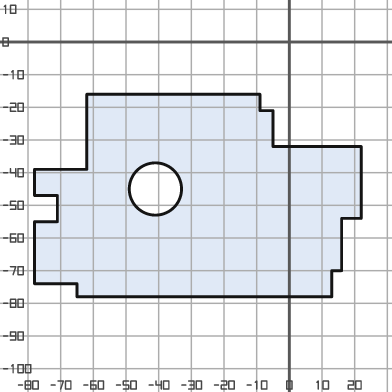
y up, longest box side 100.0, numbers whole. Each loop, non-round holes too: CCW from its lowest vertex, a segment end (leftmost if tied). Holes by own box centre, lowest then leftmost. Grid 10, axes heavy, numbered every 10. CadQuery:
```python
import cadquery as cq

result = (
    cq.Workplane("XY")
    .moveTo(-65.0, -78.0)
    .lineTo(13.0, -78.0)
    .lineTo(13.0, -70.0)
    .lineTo(16.0, -70.0)
    .lineTo(16.0, -54.0)
    .lineTo(22.0, -54.0)
    .lineTo(22.0, -32.0)
    .lineTo(-5.0, -32.0)
    .lineTo(-5.0, -21.0)
    .lineTo(-9.0, -21.0)
    .lineTo(-9.0, -16.0)
    .lineTo(-62.0, -16.0)
    .lineTo(-62.0, -39.0)
    .lineTo(-78.0, -39.0)
    .lineTo(-78.0, -47.0)
    .lineTo(-71.0, -47.0)
    .lineTo(-71.0, -55.0)
    .lineTo(-78.0, -55.0)
    .lineTo(-78.0, -74.0)
    .lineTo(-65.0, -74.0)
    .close()
    .moveTo(-41.0, -45.0)
    .circle(8.0)
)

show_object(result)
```